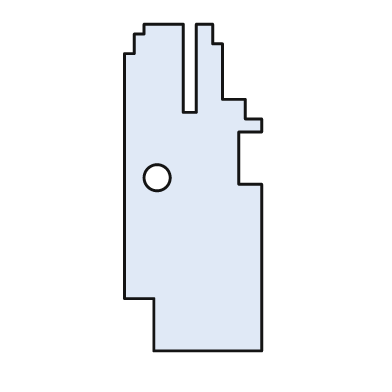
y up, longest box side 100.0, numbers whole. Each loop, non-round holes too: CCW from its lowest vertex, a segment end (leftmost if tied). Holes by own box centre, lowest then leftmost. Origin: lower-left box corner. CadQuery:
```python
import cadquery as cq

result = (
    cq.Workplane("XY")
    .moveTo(9.0, 0.0)
    .lineTo(42.0, 0.0)
    .lineTo(42.0, 51.0)
    .lineTo(35.0, 51.0)
    .lineTo(35.0, 67.0)
    .lineTo(42.0, 67.0)
    .lineTo(42.0, 71.0)
    .lineTo(37.0, 71.0)
    .lineTo(37.0, 77.0)
    .lineTo(30.0, 77.0)
    .lineTo(30.0, 94.0)
    .lineTo(27.0, 94.0)
    .lineTo(27.0, 100.0)
    .lineTo(22.0, 100.0)
    .lineTo(22.0, 73.0)
    .lineTo(18.0, 73.0)
    .lineTo(18.0, 100.0)
    .lineTo(6.0, 100.0)
    .lineTo(6.0, 97.0)
    .lineTo(3.0, 97.0)
    .lineTo(3.0, 91.0)
    .lineTo(0.0, 91.0)
    .lineTo(0.0, 16.0)
    .lineTo(9.0, 16.0)
    .close()
    .moveTo(10.0, 53.0)
    .circle(4.0)
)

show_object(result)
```